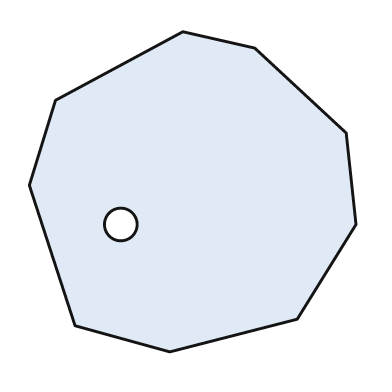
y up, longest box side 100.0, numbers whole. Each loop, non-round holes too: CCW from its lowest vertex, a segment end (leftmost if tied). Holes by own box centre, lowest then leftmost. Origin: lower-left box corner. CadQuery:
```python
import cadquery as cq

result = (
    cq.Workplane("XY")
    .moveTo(43.0, 0.0)
    .lineTo(82.0, 10.0)
    .lineTo(100.0, 39.0)
    .lineTo(97.0, 67.0)
    .lineTo(69.0, 93.0)
    .lineTo(47.0, 98.0)
    .lineTo(8.0, 77.0)
    .lineTo(0.0, 51.0)
    .lineTo(14.0, 8.0)
    .close()
    .moveTo(28.0, 39.0)
    .circle(5.0)
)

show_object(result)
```